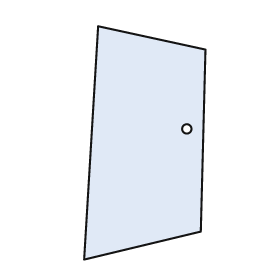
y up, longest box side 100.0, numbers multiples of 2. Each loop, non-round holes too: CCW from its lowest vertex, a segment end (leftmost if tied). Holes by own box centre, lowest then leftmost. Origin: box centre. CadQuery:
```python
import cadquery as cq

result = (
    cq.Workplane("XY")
    .moveTo(-26.0, -50.0)
    .lineTo(24.0, -38.0)
    .lineTo(26.0, 40.0)
    .lineTo(-20.0, 50.0)
    .close()
    .moveTo(18.0, 6.0)
    .circle(2.0)
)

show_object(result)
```